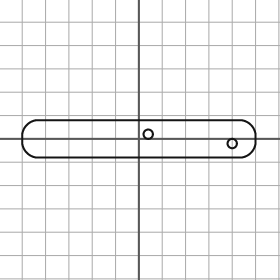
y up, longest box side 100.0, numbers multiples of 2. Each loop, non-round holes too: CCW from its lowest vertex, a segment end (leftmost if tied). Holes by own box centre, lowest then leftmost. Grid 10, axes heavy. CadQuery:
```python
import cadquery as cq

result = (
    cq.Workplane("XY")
    .moveTo(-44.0, -8.0)
    .lineTo(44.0, -8.0)
    .threePointArc((48.0, -6.0), (50.0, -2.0))
    .lineTo(50.0, 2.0)
    .threePointArc((48.0, 6.0), (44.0, 8.0))
    .lineTo(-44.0, 8.0)
    .threePointArc((-48.0, 6.0), (-50.0, 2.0))
    .lineTo(-50.0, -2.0)
    .threePointArc((-48.0, -6.0), (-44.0, -8.0))
    .close()
    .moveTo(40.0, -2.0)
    .circle(2.0)
    .moveTo(4.0, 2.0)
    .circle(2.0)
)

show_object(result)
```